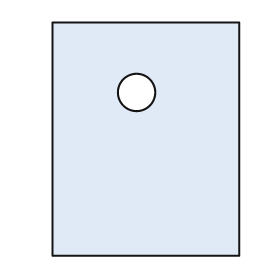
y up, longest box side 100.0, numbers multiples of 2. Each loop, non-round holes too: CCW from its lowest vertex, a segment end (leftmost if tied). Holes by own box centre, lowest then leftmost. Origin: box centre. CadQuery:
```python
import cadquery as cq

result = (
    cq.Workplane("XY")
    .moveTo(-40.0, -50.0)
    .lineTo(40.0, -50.0)
    .lineTo(40.0, 50.0)
    .lineTo(-40.0, 50.0)
    .close()
    .moveTo(-4.0, 20.0)
    .circle(8.0)
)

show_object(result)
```